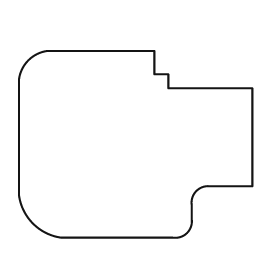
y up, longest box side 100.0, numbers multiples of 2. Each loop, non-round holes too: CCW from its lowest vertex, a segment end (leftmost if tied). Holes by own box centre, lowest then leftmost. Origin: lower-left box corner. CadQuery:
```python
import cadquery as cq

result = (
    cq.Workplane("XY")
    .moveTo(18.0, 0.0)
    .lineTo(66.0, 0.0)
    .threePointArc((72.0, 2.0), (74.0, 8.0))
    .lineTo(74.0, 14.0)
    .threePointArc((76.0, 20.0), (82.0, 22.0))
    .lineTo(100.0, 22.0)
    .lineTo(100.0, 64.0)
    .lineTo(64.0, 64.0)
    .lineTo(64.0, 70.0)
    .lineTo(58.0, 70.0)
    .lineTo(58.0, 80.0)
    .lineTo(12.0, 80.0)
    .threePointArc((4.0, 76.0), (0.0, 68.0))
    .lineTo(0.0, 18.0)
    .threePointArc((6.0, 6.0), (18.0, 0.0))
    .close()
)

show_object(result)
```